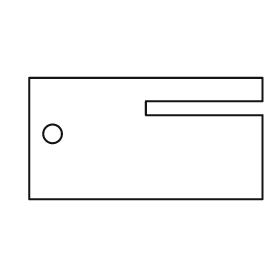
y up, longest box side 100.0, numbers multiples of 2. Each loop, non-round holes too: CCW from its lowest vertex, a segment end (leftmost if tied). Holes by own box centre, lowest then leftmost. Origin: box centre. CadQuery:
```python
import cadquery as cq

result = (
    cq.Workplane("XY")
    .moveTo(-50.0, -26.0)
    .lineTo(50.0, -26.0)
    .lineTo(50.0, 10.0)
    .lineTo(0.0, 10.0)
    .lineTo(0.0, 16.0)
    .lineTo(50.0, 16.0)
    .lineTo(50.0, 26.0)
    .lineTo(-50.0, 26.0)
    .close()
    .moveTo(-40.0, 2.0)
    .circle(4.0)
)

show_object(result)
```